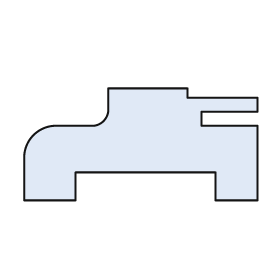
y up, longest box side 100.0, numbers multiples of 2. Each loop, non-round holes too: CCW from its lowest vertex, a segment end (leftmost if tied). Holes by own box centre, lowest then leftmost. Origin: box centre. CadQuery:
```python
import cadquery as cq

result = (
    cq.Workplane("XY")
    .moveTo(-50.0, -24.0)
    .lineTo(-28.0, -24.0)
    .lineTo(-28.0, -12.0)
    .lineTo(32.0, -12.0)
    .lineTo(32.0, -24.0)
    .lineTo(50.0, -24.0)
    .lineTo(50.0, 8.0)
    .lineTo(26.0, 8.0)
    .lineTo(26.0, 14.0)
    .lineTo(50.0, 14.0)
    .lineTo(50.0, 20.0)
    .lineTo(20.0, 20.0)
    .lineTo(20.0, 24.0)
    .lineTo(-14.0, 24.0)
    .lineTo(-14.0, 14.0)
    .threePointArc((-16.0, 10.0), (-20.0, 8.0))
    .lineTo(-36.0, 8.0)
    .threePointArc((-46.0, 4.0), (-50.0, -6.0))
    .close()
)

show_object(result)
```